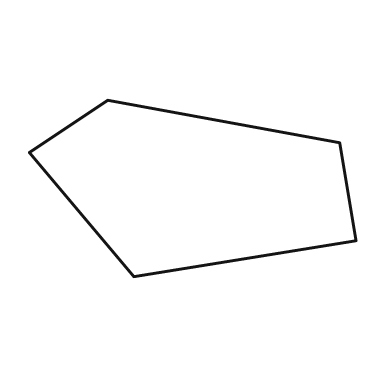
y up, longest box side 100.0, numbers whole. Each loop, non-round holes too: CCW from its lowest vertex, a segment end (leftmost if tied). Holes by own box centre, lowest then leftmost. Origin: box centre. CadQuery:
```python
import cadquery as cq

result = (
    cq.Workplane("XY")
    .moveTo(-18.0, -27.0)
    .lineTo(50.0, -16.0)
    .lineTo(45.0, 14.0)
    .lineTo(-26.0, 27.0)
    .lineTo(-50.0, 11.0)
    .close()
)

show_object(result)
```